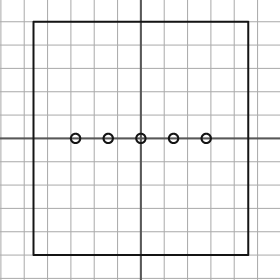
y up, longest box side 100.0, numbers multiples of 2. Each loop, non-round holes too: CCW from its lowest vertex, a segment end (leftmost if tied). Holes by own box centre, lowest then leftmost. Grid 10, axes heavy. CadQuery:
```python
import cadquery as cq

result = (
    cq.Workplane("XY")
    .moveTo(-46.0, -50.0)
    .lineTo(46.0, -50.0)
    .lineTo(46.0, 50.0)
    .lineTo(-46.0, 50.0)
    .close()
    .moveTo(-28.0, 0.0)
    .circle(2.0)
    .moveTo(-14.0, 0.0)
    .circle(2.0)
    .moveTo(0.0, 0.0)
    .circle(2.0)
    .moveTo(14.0, 0.0)
    .circle(2.0)
    .moveTo(28.0, 0.0)
    .circle(2.0)
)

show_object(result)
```